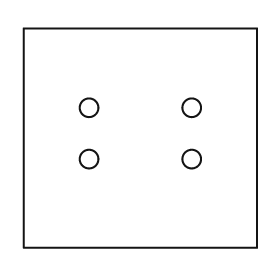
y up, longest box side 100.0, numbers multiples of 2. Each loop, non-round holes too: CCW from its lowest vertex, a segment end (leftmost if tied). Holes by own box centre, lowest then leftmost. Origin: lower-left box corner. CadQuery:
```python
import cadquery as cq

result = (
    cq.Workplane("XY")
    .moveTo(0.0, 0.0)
    .lineTo(100.0, 0.0)
    .lineTo(100.0, 94.0)
    .lineTo(0.0, 94.0)
    .close()
    .moveTo(28.0, 38.0)
    .circle(4.0)
    .moveTo(72.0, 38.0)
    .circle(4.0)
    .moveTo(28.0, 60.0)
    .circle(4.0)
    .moveTo(72.0, 60.0)
    .circle(4.0)
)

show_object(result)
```